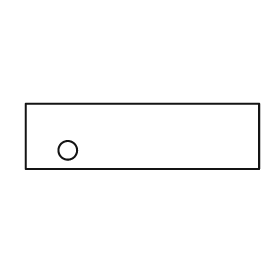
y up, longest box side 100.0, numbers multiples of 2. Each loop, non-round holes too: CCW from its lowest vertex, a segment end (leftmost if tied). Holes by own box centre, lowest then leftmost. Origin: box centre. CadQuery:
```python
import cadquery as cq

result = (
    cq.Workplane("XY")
    .moveTo(-50.0, -14.0)
    .lineTo(50.0, -14.0)
    .lineTo(50.0, 14.0)
    .lineTo(-50.0, 14.0)
    .close()
    .moveTo(-32.0, -6.0)
    .circle(4.0)
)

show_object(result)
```